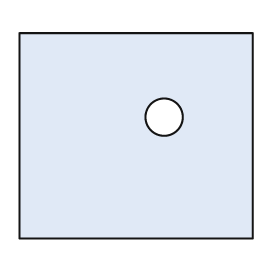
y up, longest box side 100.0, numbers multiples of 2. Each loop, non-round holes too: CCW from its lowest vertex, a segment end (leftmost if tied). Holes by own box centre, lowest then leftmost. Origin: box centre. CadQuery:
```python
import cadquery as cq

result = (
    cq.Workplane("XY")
    .moveTo(-50.0, -44.0)
    .lineTo(50.0, -44.0)
    .lineTo(50.0, 44.0)
    .lineTo(-50.0, 44.0)
    .close()
    .moveTo(12.0, 8.0)
    .circle(8.0)
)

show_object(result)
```